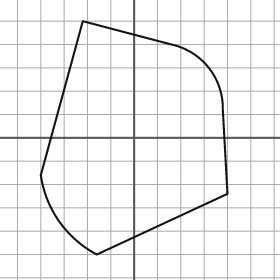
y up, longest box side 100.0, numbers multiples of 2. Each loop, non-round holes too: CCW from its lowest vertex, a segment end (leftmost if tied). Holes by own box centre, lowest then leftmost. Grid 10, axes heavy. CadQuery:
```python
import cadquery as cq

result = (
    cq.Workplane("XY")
    .moveTo(-16.0, -50.0)
    .lineTo(40.0, -24.0)
    .lineTo(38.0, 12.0)
    .threePointArc((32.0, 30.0), (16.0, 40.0))
    .lineTo(-22.0, 50.0)
    .lineTo(-40.0, -16.0)
    .threePointArc((-32.0, -36.0), (-16.0, -50.0))
    .close()
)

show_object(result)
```